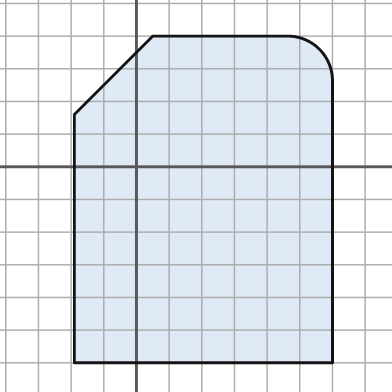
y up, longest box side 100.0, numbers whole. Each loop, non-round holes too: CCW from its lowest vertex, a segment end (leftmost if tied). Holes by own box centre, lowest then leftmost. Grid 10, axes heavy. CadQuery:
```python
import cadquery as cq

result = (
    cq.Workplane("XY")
    .moveTo(-19.0, -60.0)
    .lineTo(60.0, -60.0)
    .lineTo(60.0, 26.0)
    .threePointArc((56.0, 36.0), (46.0, 40.0))
    .lineTo(5.0, 40.0)
    .lineTo(-19.0, 16.0)
    .close()
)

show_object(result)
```